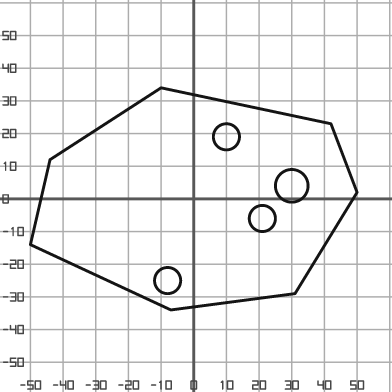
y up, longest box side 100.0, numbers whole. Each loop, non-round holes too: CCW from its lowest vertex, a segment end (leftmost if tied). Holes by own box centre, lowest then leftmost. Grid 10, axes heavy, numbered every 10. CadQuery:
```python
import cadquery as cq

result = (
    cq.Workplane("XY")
    .moveTo(-7.0, -34.0)
    .lineTo(31.0, -29.0)
    .lineTo(50.0, 2.0)
    .lineTo(42.0, 23.0)
    .lineTo(-10.0, 34.0)
    .lineTo(-44.0, 12.0)
    .lineTo(-50.0, -14.0)
    .close()
    .moveTo(-8.0, -25.0)
    .circle(4.0)
    .moveTo(21.0, -6.0)
    .circle(4.0)
    .moveTo(30.0, 4.0)
    .circle(5.0)
    .moveTo(10.0, 19.0)
    .circle(4.0)
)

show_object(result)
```